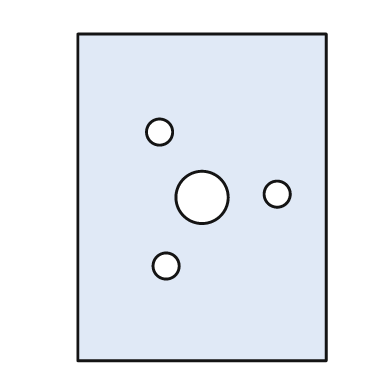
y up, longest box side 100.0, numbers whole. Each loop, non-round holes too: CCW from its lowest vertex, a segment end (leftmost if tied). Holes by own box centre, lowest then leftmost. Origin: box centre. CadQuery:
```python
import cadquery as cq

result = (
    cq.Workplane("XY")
    .moveTo(-38.0, -50.0)
    .lineTo(38.0, -50.0)
    .lineTo(38.0, 50.0)
    .lineTo(-38.0, 50.0)
    .close()
    .moveTo(-11.0, -21.0)
    .circle(4.0)
    .moveTo(0.0, 0.0)
    .circle(8.0)
    .moveTo(23.0, 1.0)
    .circle(4.0)
    .moveTo(-13.0, 20.0)
    .circle(4.0)
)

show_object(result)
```